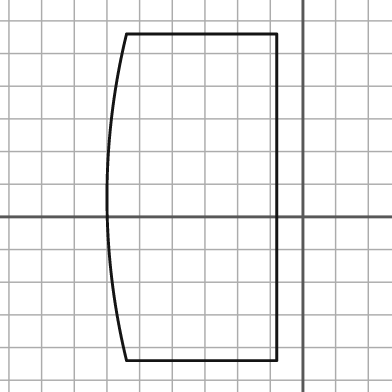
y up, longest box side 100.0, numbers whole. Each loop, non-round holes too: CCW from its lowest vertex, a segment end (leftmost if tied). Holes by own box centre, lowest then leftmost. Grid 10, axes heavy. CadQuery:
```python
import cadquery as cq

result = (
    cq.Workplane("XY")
    .moveTo(-54.0, -44.0)
    .lineTo(-8.0, -44.0)
    .lineTo(-8.0, 56.0)
    .lineTo(-54.0, 56.0)
    .threePointArc((-60.0, 6.0), (-54.0, -44.0))
    .close()
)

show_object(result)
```